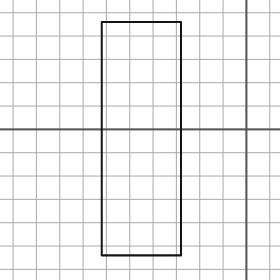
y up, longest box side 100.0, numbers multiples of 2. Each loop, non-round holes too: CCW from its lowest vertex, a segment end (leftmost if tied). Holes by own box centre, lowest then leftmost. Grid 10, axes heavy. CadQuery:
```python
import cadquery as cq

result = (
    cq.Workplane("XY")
    .moveTo(-62.0, -54.0)
    .lineTo(-28.0, -54.0)
    .lineTo(-28.0, 46.0)
    .lineTo(-62.0, 46.0)
    .close()
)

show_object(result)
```